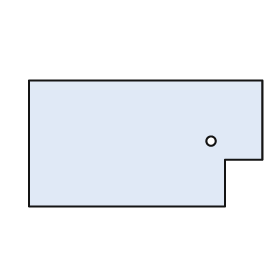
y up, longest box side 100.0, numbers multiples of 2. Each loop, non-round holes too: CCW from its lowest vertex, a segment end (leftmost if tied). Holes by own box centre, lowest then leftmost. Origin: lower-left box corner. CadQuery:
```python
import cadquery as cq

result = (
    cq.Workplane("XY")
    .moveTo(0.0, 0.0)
    .lineTo(84.0, 0.0)
    .lineTo(84.0, 20.0)
    .lineTo(100.0, 20.0)
    .lineTo(100.0, 54.0)
    .lineTo(0.0, 54.0)
    .close()
    .moveTo(78.0, 28.0)
    .circle(2.0)
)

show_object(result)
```